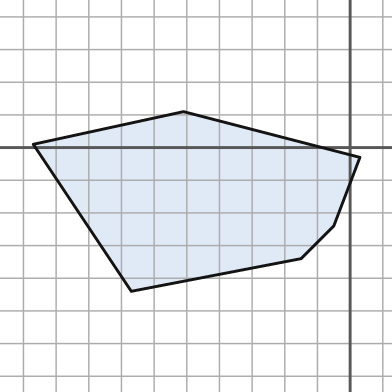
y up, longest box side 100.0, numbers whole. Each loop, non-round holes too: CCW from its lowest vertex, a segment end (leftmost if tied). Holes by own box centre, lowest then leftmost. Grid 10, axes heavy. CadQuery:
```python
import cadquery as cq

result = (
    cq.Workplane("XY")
    .moveTo(-67.0, -44.0)
    .lineTo(-15.0, -34.0)
    .lineTo(-5.0, -24.0)
    .lineTo(3.0, -3.0)
    .lineTo(-51.0, 11.0)
    .lineTo(-97.0, 1.0)
    .close()
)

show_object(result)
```